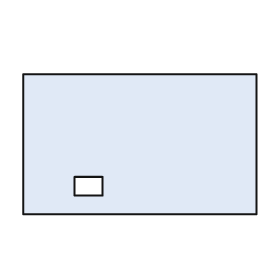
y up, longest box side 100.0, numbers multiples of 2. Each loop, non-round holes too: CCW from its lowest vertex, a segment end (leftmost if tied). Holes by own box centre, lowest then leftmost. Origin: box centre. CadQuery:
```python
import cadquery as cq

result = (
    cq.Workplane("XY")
    .moveTo(-50.0, -30.0)
    .lineTo(50.0, -30.0)
    .lineTo(50.0, 30.0)
    .lineTo(-50.0, 30.0)
    .close()
    .moveTo(-28.0, -22.0)
    .lineTo(-16.0, -22.0)
    .lineTo(-16.0, -14.0)
    .lineTo(-28.0, -14.0)
    .close()
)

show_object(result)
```